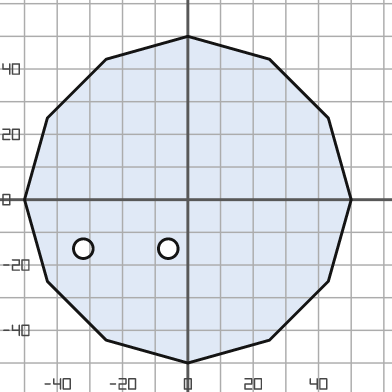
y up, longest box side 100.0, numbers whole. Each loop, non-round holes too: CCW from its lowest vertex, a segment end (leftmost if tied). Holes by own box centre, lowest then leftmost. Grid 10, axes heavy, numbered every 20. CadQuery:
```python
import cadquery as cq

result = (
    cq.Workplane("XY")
    .moveTo(0.0, -50.0)
    .lineTo(25.0, -43.0)
    .lineTo(43.0, -25.0)
    .lineTo(50.0, 0.0)
    .lineTo(43.0, 25.0)
    .lineTo(25.0, 43.0)
    .lineTo(0.0, 50.0)
    .lineTo(-25.0, 43.0)
    .lineTo(-43.0, 25.0)
    .lineTo(-50.0, 0.0)
    .lineTo(-43.0, -25.0)
    .lineTo(-25.0, -43.0)
    .close()
    .moveTo(-32.0, -15.0)
    .circle(3.0)
    .moveTo(-6.0, -15.0)
    .circle(3.0)
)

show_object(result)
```